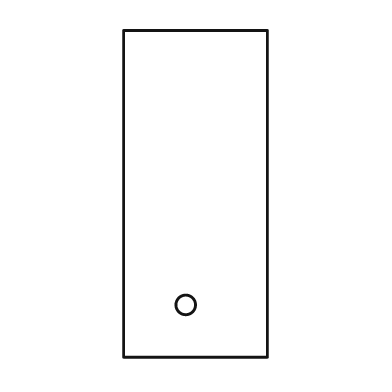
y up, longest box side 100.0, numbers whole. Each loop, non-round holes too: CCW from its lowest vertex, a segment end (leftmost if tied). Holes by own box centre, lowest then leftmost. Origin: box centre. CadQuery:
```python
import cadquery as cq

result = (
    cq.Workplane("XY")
    .moveTo(-22.0, -50.0)
    .lineTo(22.0, -50.0)
    .lineTo(22.0, 50.0)
    .lineTo(-22.0, 50.0)
    .close()
    .moveTo(-3.0, -34.0)
    .circle(3.0)
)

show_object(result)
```